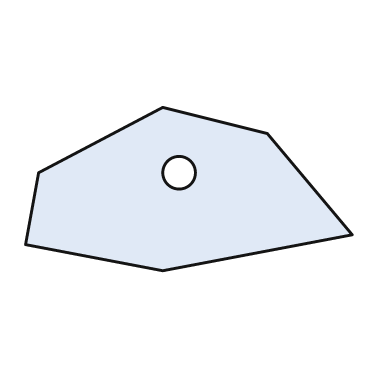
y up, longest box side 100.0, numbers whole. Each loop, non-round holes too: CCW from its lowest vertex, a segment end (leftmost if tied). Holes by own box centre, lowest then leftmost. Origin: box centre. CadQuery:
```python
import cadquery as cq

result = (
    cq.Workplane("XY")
    .moveTo(-8.0, -25.0)
    .lineTo(50.0, -14.0)
    .lineTo(24.0, 17.0)
    .lineTo(-8.0, 25.0)
    .lineTo(-46.0, 5.0)
    .lineTo(-50.0, -17.0)
    .close()
    .moveTo(-3.0, 5.0)
    .circle(5.0)
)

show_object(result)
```